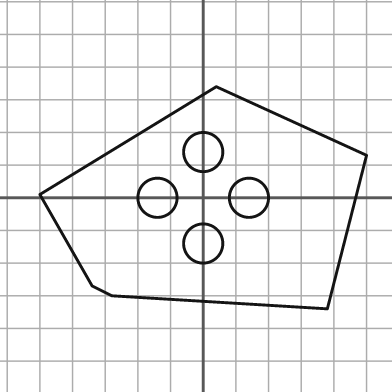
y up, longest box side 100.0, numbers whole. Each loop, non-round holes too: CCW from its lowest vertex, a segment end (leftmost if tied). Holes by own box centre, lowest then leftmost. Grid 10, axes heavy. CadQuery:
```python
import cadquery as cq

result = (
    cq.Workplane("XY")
    .moveTo(38.0, -34.0)
    .lineTo(50.0, 13.0)
    .lineTo(4.0, 34.0)
    .lineTo(-50.0, 1.0)
    .lineTo(-34.0, -27.0)
    .lineTo(-28.0, -30.0)
    .close()
    .moveTo(0.0, -14.0)
    .circle(6.0)
    .moveTo(-14.0, 0.0)
    .circle(6.0)
    .moveTo(14.0, 0.0)
    .circle(6.0)
    .moveTo(0.0, 14.0)
    .circle(6.0)
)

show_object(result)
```